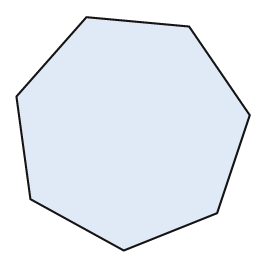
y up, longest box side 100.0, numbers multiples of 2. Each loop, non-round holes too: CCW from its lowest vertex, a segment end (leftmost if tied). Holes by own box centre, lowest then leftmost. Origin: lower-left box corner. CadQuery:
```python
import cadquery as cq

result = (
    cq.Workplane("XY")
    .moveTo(46.0, 0.0)
    .lineTo(86.0, 16.0)
    .lineTo(100.0, 58.0)
    .lineTo(74.0, 96.0)
    .lineTo(30.0, 100.0)
    .lineTo(0.0, 66.0)
    .lineTo(6.0, 22.0)
    .close()
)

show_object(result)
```